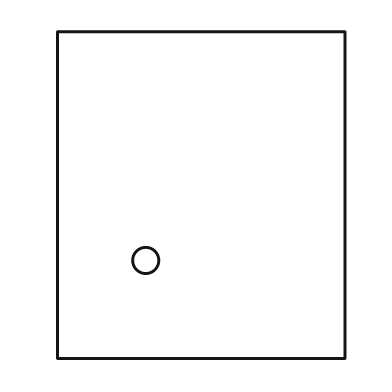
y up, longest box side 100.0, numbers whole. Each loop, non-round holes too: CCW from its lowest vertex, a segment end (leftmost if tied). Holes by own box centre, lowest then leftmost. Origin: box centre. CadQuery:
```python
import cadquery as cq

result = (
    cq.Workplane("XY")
    .moveTo(-44.0, -50.0)
    .lineTo(44.0, -50.0)
    .lineTo(44.0, 50.0)
    .lineTo(-44.0, 50.0)
    .close()
    .moveTo(-17.0, -20.0)
    .circle(4.0)
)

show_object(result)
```